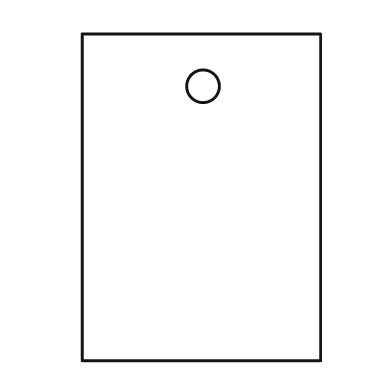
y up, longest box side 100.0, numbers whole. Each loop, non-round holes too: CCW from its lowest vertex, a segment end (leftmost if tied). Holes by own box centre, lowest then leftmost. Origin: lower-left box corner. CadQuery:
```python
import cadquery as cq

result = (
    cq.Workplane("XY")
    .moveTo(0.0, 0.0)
    .lineTo(73.0, 0.0)
    .lineTo(73.0, 100.0)
    .lineTo(0.0, 100.0)
    .close()
    .moveTo(37.0, 84.0)
    .circle(5.0)
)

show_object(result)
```